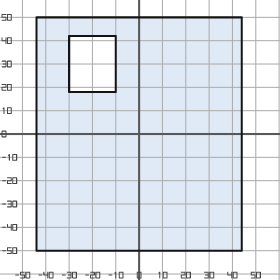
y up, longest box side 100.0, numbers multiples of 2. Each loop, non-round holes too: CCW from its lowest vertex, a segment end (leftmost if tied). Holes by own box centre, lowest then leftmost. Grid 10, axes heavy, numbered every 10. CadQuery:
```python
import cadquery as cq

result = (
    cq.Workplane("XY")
    .moveTo(-44.0, -50.0)
    .lineTo(44.0, -50.0)
    .lineTo(44.0, 50.0)
    .lineTo(-44.0, 50.0)
    .close()
    .moveTo(-30.0, 18.0)
    .lineTo(-10.0, 18.0)
    .lineTo(-10.0, 42.0)
    .lineTo(-30.0, 42.0)
    .close()
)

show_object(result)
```